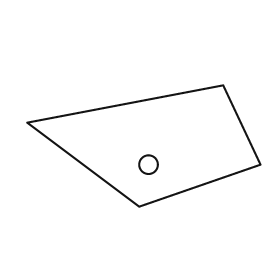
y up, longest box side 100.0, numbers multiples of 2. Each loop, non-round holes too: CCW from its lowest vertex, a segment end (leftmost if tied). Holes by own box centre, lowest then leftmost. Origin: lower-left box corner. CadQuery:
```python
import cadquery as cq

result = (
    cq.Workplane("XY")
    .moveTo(48.0, 0.0)
    .lineTo(100.0, 18.0)
    .lineTo(84.0, 52.0)
    .lineTo(0.0, 36.0)
    .close()
    .moveTo(52.0, 18.0)
    .circle(4.0)
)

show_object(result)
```